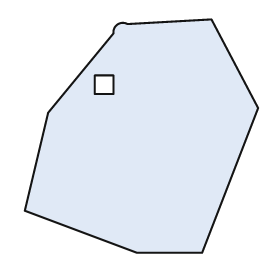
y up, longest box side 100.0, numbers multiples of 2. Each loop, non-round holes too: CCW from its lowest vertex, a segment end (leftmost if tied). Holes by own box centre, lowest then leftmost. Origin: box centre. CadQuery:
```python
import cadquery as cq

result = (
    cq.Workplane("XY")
    .moveTo(-2.0, -50.0)
    .lineTo(26.0, -50.0)
    .lineTo(50.0, 12.0)
    .lineTo(30.0, 50.0)
    .lineTo(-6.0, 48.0)
    .threePointArc((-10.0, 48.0), (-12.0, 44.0))
    .lineTo(-40.0, 10.0)
    .lineTo(-50.0, -32.0)
    .close()
    .moveTo(-20.0, 18.0)
    .lineTo(-12.0, 18.0)
    .lineTo(-12.0, 26.0)
    .lineTo(-20.0, 26.0)
    .close()
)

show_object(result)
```